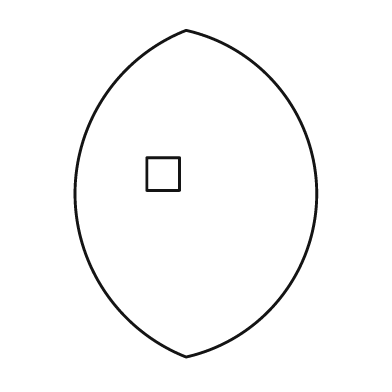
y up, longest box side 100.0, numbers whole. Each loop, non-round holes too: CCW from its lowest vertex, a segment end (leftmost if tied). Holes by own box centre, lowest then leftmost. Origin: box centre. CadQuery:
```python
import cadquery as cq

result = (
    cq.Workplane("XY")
    .moveTo(-3.0, -50.0)
    .threePointArc((37.0, 0.0), (-3.0, 50.0))
    .threePointArc((-37.0, 0.0), (-3.0, -50.0))
    .close()
    .moveTo(-15.0, 1.0)
    .lineTo(-5.0, 1.0)
    .lineTo(-5.0, 11.0)
    .lineTo(-15.0, 11.0)
    .close()
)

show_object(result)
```